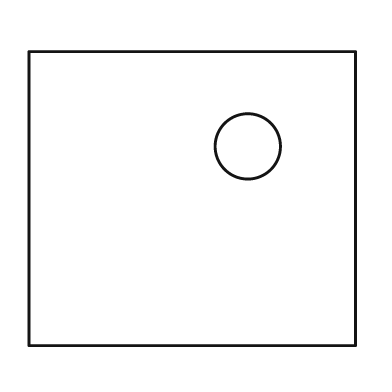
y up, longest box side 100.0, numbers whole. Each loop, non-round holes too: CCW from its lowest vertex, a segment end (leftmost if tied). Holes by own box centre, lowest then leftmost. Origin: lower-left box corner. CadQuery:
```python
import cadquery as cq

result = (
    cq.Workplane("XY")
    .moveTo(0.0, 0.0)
    .lineTo(100.0, 0.0)
    .lineTo(100.0, 90.0)
    .lineTo(0.0, 90.0)
    .close()
    .moveTo(67.0, 61.0)
    .circle(10.0)
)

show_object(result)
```